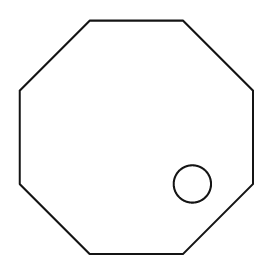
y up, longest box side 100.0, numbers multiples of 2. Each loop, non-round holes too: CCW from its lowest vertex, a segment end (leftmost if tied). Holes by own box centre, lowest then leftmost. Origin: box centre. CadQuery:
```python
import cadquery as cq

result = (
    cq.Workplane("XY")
    .moveTo(-20.0, -50.0)
    .lineTo(20.0, -50.0)
    .lineTo(50.0, -20.0)
    .lineTo(50.0, 20.0)
    .lineTo(20.0, 50.0)
    .lineTo(-20.0, 50.0)
    .lineTo(-50.0, 20.0)
    .lineTo(-50.0, -20.0)
    .close()
    .moveTo(24.0, -20.0)
    .circle(8.0)
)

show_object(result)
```